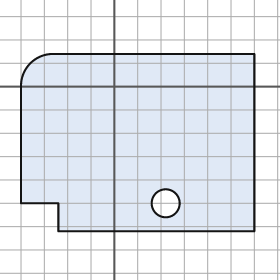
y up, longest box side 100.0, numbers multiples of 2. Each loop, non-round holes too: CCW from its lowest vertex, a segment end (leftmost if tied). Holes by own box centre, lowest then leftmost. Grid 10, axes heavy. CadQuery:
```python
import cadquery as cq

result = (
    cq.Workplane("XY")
    .moveTo(-24.0, -62.0)
    .lineTo(60.0, -62.0)
    .lineTo(60.0, 14.0)
    .lineTo(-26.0, 14.0)
    .threePointArc((-36.0, 10.0), (-40.0, 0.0))
    .lineTo(-40.0, -50.0)
    .lineTo(-24.0, -50.0)
    .close()
    .moveTo(22.0, -50.0)
    .circle(6.0)
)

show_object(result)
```